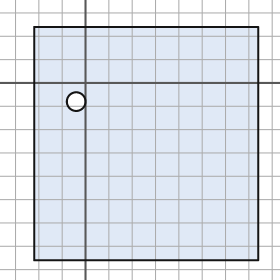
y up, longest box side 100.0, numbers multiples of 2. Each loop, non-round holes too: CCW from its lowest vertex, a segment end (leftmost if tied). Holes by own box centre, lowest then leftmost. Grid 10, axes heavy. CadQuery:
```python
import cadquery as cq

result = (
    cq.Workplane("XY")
    .moveTo(-22.0, -76.0)
    .lineTo(74.0, -76.0)
    .lineTo(74.0, 24.0)
    .lineTo(-22.0, 24.0)
    .close()
    .moveTo(-4.0, -8.0)
    .circle(4.0)
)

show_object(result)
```